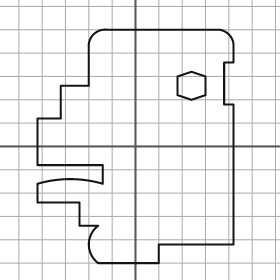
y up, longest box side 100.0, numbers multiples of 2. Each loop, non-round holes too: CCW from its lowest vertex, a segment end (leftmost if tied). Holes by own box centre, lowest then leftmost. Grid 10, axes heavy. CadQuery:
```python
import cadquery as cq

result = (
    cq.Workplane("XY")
    .moveTo(-16.0, -50.0)
    .lineTo(10.0, -50.0)
    .lineTo(10.0, -42.0)
    .lineTo(42.0, -42.0)
    .lineTo(42.0, 18.0)
    .lineTo(38.0, 18.0)
    .lineTo(38.0, 36.0)
    .lineTo(42.0, 36.0)
    .lineTo(42.0, 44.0)
    .threePointArc((40.0, 48.0), (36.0, 50.0))
    .lineTo(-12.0, 50.0)
    .threePointArc((-18.0, 48.0), (-20.0, 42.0))
    .lineTo(-20.0, 26.0)
    .lineTo(-32.0, 26.0)
    .lineTo(-32.0, 12.0)
    .lineTo(-42.0, 12.0)
    .lineTo(-42.0, -8.0)
    .lineTo(-14.0, -8.0)
    .lineTo(-14.0, -16.0)
    .threePointArc((-28.0, -14.0), (-42.0, -16.0))
    .lineTo(-42.0, -24.0)
    .lineTo(-24.0, -24.0)
    .lineTo(-24.0, -34.0)
    .lineTo(-16.0, -34.0)
    .threePointArc((-20.0, -42.0), (-16.0, -50.0))
    .close()
    .moveTo(24.0, 20.0)
    .lineTo(30.0, 22.0)
    .lineTo(30.0, 30.0)
    .lineTo(24.0, 32.0)
    .lineTo(18.0, 30.0)
    .lineTo(18.0, 22.0)
    .close()
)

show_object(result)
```